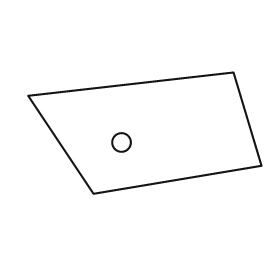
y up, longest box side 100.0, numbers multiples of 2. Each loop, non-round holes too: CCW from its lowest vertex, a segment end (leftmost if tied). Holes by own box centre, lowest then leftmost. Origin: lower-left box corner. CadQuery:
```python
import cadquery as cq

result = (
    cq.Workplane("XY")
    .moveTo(28.0, 0.0)
    .lineTo(100.0, 12.0)
    .lineTo(88.0, 52.0)
    .lineTo(0.0, 42.0)
    .close()
    .moveTo(40.0, 22.0)
    .circle(4.0)
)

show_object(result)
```